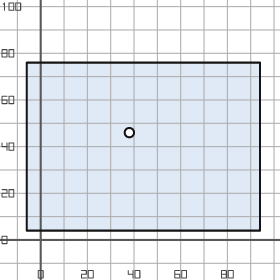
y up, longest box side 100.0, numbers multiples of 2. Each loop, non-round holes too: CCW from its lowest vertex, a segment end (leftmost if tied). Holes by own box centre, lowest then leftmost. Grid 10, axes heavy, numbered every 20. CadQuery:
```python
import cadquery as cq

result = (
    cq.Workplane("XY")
    .moveTo(-6.0, 4.0)
    .lineTo(94.0, 4.0)
    .lineTo(94.0, 76.0)
    .lineTo(-6.0, 76.0)
    .close()
    .moveTo(38.0, 46.0)
    .circle(2.0)
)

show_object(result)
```